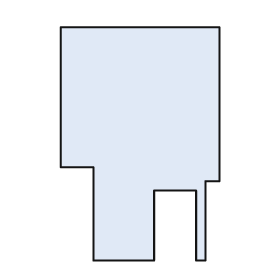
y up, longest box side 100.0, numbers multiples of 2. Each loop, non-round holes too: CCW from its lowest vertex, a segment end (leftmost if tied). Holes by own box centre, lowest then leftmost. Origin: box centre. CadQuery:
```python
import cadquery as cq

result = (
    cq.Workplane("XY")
    .moveTo(-20.0, -50.0)
    .lineTo(6.0, -50.0)
    .lineTo(6.0, -20.0)
    .lineTo(24.0, -20.0)
    .lineTo(24.0, -50.0)
    .lineTo(28.0, -50.0)
    .lineTo(28.0, -16.0)
    .lineTo(34.0, -16.0)
    .lineTo(34.0, 50.0)
    .lineTo(-34.0, 50.0)
    .lineTo(-34.0, -10.0)
    .lineTo(-20.0, -10.0)
    .close()
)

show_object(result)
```